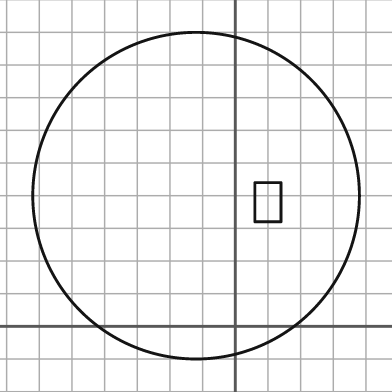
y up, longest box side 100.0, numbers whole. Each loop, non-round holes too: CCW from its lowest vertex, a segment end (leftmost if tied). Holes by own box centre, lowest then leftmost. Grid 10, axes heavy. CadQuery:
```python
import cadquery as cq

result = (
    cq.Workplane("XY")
    .moveTo(-12.0, 40.0)
    .circle(50.0)
    .moveTo(6.0, 32.0)
    .lineTo(14.0, 32.0)
    .lineTo(14.0, 44.0)
    .lineTo(6.0, 44.0)
    .close()
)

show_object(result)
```